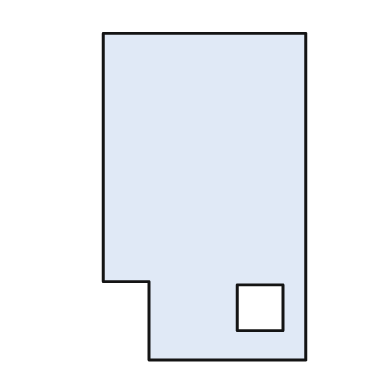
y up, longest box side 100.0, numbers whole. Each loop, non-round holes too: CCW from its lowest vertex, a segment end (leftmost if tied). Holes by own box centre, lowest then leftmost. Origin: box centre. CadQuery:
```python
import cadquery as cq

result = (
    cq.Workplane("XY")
    .moveTo(-17.0, -50.0)
    .lineTo(31.0, -50.0)
    .lineTo(31.0, 50.0)
    .lineTo(-31.0, 50.0)
    .lineTo(-31.0, -26.0)
    .lineTo(-17.0, -26.0)
    .close()
    .moveTo(10.0, -41.0)
    .lineTo(24.0, -41.0)
    .lineTo(24.0, -27.0)
    .lineTo(10.0, -27.0)
    .close()
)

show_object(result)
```